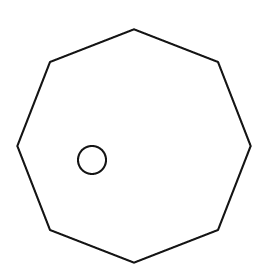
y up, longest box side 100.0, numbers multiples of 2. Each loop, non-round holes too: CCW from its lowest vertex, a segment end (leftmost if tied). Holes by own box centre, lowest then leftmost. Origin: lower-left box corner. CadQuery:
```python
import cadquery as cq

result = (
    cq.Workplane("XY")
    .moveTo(50.0, 0.0)
    .lineTo(86.0, 14.0)
    .lineTo(100.0, 50.0)
    .lineTo(86.0, 86.0)
    .lineTo(50.0, 100.0)
    .lineTo(14.0, 86.0)
    .lineTo(0.0, 50.0)
    .lineTo(14.0, 14.0)
    .close()
    .moveTo(32.0, 44.0)
    .circle(6.0)
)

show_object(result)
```